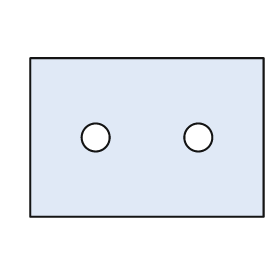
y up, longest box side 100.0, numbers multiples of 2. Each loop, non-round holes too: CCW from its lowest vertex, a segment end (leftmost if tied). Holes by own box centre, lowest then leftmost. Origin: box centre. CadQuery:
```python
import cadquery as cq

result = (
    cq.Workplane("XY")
    .moveTo(-50.0, -34.0)
    .lineTo(50.0, -34.0)
    .lineTo(50.0, 34.0)
    .lineTo(-50.0, 34.0)
    .close()
    .moveTo(-22.0, 0.0)
    .circle(6.0)
    .moveTo(22.0, 0.0)
    .circle(6.0)
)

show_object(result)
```